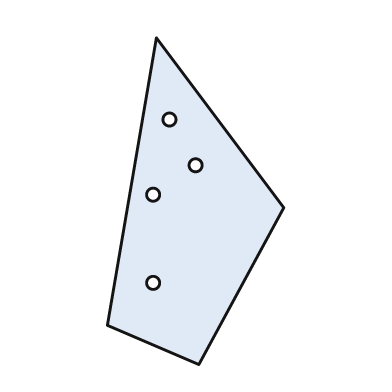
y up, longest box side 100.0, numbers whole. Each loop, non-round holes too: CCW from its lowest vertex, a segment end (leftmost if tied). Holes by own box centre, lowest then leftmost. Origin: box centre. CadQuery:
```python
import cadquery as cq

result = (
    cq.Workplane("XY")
    .moveTo(1.0, -50.0)
    .lineTo(27.0, -2.0)
    .lineTo(-12.0, 50.0)
    .lineTo(-27.0, -38.0)
    .close()
    .moveTo(-13.0, -25.0)
    .circle(2.0)
    .moveTo(-13.0, 2.0)
    .circle(2.0)
    .moveTo(0.0, 11.0)
    .circle(2.0)
    .moveTo(-8.0, 25.0)
    .circle(2.0)
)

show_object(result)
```